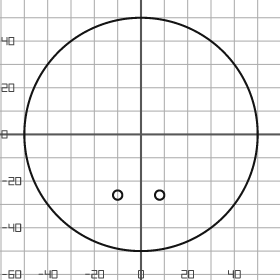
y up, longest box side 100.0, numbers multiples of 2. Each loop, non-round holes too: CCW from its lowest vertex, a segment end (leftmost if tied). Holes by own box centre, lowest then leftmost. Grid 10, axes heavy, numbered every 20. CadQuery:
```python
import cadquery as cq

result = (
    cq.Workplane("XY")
    .moveTo(0.0, 0.0)
    .circle(50.0)
    .moveTo(-10.0, -26.0)
    .circle(2.0)
    .moveTo(8.0, -26.0)
    .circle(2.0)
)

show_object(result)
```